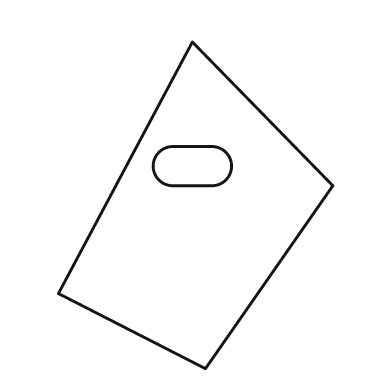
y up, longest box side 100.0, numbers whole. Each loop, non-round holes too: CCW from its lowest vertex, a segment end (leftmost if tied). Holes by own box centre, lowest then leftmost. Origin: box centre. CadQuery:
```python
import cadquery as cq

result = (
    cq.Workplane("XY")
    .moveTo(3.0, -50.0)
    .lineTo(42.0, 6.0)
    .lineTo(-1.0, 50.0)
    .lineTo(-42.0, -27.0)
    .close()
    .moveTo(-7.0, 6.0)
    .lineTo(5.0, 6.0)
    .threePointArc((11.0, 12.0), (5.0, 18.0))
    .lineTo(-7.0, 18.0)
    .threePointArc((-13.0, 12.0), (-7.0, 6.0))
    .close()
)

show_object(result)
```